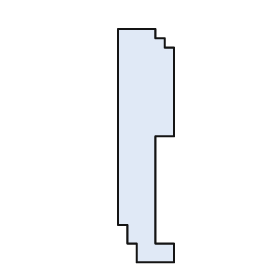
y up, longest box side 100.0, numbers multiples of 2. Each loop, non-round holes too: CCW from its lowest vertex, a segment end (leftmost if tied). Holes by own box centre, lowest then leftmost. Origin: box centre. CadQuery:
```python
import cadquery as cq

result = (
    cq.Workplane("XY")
    .moveTo(-4.0, -50.0)
    .lineTo(12.0, -50.0)
    .lineTo(12.0, -42.0)
    .lineTo(4.0, -42.0)
    .lineTo(4.0, 4.0)
    .lineTo(12.0, 4.0)
    .lineTo(12.0, 42.0)
    .lineTo(8.0, 42.0)
    .lineTo(8.0, 46.0)
    .lineTo(4.0, 46.0)
    .lineTo(4.0, 50.0)
    .lineTo(-12.0, 50.0)
    .lineTo(-12.0, -34.0)
    .lineTo(-8.0, -34.0)
    .lineTo(-8.0, -42.0)
    .lineTo(-4.0, -42.0)
    .close()
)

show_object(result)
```